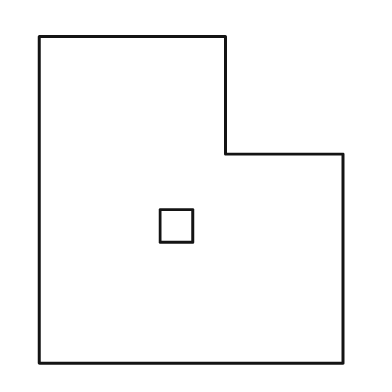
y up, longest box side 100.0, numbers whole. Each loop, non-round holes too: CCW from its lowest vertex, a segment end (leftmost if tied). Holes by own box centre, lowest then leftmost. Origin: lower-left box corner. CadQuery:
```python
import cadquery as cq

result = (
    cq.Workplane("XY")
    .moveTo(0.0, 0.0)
    .lineTo(93.0, 0.0)
    .lineTo(93.0, 64.0)
    .lineTo(57.0, 64.0)
    .lineTo(57.0, 100.0)
    .lineTo(0.0, 100.0)
    .close()
    .moveTo(37.0, 37.0)
    .lineTo(47.0, 37.0)
    .lineTo(47.0, 47.0)
    .lineTo(37.0, 47.0)
    .close()
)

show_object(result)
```